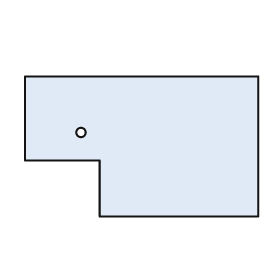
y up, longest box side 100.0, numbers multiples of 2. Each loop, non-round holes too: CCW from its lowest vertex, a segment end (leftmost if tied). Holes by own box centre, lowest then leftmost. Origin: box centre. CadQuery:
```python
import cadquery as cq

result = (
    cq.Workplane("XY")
    .moveTo(-18.0, -30.0)
    .lineTo(50.0, -30.0)
    .lineTo(50.0, 30.0)
    .lineTo(-50.0, 30.0)
    .lineTo(-50.0, -6.0)
    .lineTo(-18.0, -6.0)
    .close()
    .moveTo(-26.0, 6.0)
    .circle(2.0)
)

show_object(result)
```